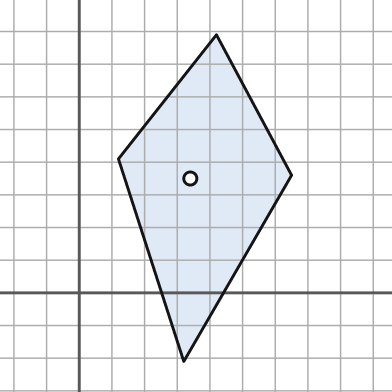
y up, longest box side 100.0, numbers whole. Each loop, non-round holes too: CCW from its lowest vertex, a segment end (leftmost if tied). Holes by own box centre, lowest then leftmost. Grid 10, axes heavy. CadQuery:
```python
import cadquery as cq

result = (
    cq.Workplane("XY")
    .moveTo(32.0, -21.0)
    .lineTo(65.0, 36.0)
    .lineTo(42.0, 79.0)
    .lineTo(12.0, 41.0)
    .close()
    .moveTo(34.0, 35.0)
    .circle(2.0)
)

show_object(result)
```